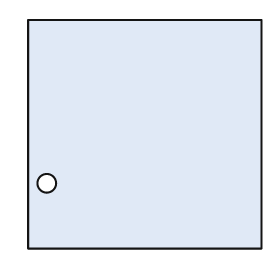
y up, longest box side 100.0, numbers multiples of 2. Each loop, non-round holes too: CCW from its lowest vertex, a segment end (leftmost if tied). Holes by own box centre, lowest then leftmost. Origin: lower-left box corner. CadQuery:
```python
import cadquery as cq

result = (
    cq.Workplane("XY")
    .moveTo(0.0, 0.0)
    .lineTo(100.0, 0.0)
    .lineTo(100.0, 98.0)
    .lineTo(0.0, 98.0)
    .close()
    .moveTo(8.0, 28.0)
    .circle(4.0)
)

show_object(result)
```